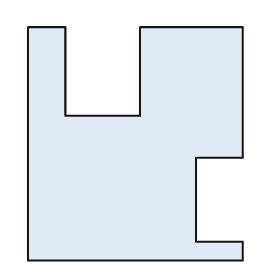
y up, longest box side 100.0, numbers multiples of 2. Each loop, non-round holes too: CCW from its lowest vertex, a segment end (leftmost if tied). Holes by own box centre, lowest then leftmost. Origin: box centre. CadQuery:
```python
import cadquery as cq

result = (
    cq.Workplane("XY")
    .moveTo(-46.0, -50.0)
    .lineTo(46.0, -50.0)
    .lineTo(46.0, -42.0)
    .lineTo(26.0, -42.0)
    .lineTo(26.0, -6.0)
    .lineTo(46.0, -6.0)
    .lineTo(46.0, 50.0)
    .lineTo(2.0, 50.0)
    .lineTo(2.0, 12.0)
    .lineTo(-30.0, 12.0)
    .lineTo(-30.0, 50.0)
    .lineTo(-46.0, 50.0)
    .close()
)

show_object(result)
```